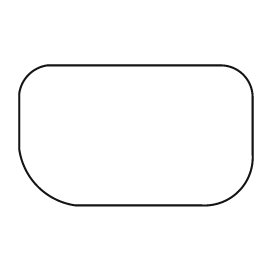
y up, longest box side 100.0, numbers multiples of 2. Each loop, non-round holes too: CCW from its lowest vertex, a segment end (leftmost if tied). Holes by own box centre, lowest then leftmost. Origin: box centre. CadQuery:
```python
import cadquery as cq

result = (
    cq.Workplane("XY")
    .moveTo(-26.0, -30.0)
    .lineTo(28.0, -30.0)
    .threePointArc((44.0, -24.0), (50.0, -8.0))
    .lineTo(50.0, 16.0)
    .threePointArc((46.0, 26.0), (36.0, 30.0))
    .lineTo(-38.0, 30.0)
    .threePointArc((-46.0, 26.0), (-50.0, 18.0))
    .lineTo(-50.0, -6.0)
    .threePointArc((-42.0, -22.0), (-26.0, -30.0))
    .close()
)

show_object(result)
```